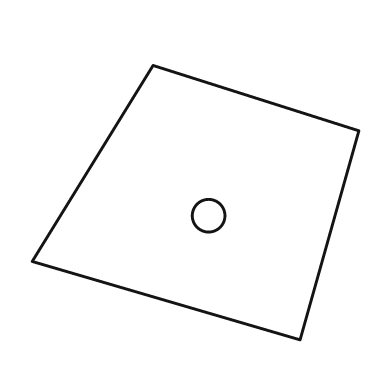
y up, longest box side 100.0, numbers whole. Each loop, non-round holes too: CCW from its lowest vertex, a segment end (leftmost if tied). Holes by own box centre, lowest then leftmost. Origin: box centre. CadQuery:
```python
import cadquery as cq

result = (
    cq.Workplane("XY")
    .moveTo(32.0, -42.0)
    .lineTo(50.0, 22.0)
    .lineTo(-13.0, 42.0)
    .lineTo(-50.0, -18.0)
    .close()
    .moveTo(4.0, -4.0)
    .circle(5.0)
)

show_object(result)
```